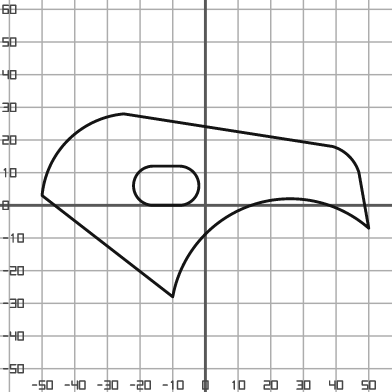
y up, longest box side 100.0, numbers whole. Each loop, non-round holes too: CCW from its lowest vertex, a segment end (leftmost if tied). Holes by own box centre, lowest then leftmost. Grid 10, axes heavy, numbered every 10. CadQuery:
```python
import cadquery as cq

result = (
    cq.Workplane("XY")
    .moveTo(-10.0, -28.0)
    .threePointArc((14.0, 0.0), (50.0, -7.0))
    .lineTo(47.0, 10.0)
    .threePointArc((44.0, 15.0), (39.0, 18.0))
    .lineTo(-25.0, 28.0)
    .threePointArc((-42.0, 20.0), (-50.0, 3.0))
    .close()
    .moveTo(-16.0, 0.0)
    .lineTo(-8.0, 0.0)
    .threePointArc((-2.0, 6.0), (-8.0, 12.0))
    .lineTo(-16.0, 12.0)
    .threePointArc((-22.0, 6.0), (-16.0, 0.0))
    .close()
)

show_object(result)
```